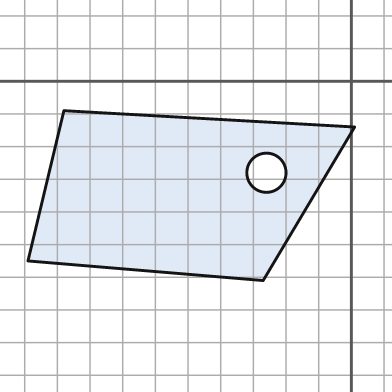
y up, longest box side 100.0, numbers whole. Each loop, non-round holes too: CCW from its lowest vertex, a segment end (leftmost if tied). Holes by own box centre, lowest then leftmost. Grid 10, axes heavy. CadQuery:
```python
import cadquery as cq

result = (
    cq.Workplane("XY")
    .moveTo(-27.0, -61.0)
    .lineTo(1.0, -14.0)
    .lineTo(-88.0, -9.0)
    .lineTo(-99.0, -55.0)
    .close()
    .moveTo(-26.0, -28.0)
    .circle(6.0)
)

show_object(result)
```